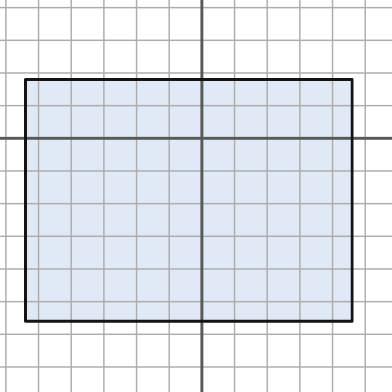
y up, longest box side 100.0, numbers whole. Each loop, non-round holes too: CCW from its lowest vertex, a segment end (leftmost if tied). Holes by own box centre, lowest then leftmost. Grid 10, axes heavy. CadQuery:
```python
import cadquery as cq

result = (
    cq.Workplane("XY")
    .moveTo(-54.0, -56.0)
    .lineTo(46.0, -56.0)
    .lineTo(46.0, 18.0)
    .lineTo(-54.0, 18.0)
    .close()
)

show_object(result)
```